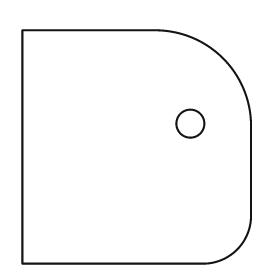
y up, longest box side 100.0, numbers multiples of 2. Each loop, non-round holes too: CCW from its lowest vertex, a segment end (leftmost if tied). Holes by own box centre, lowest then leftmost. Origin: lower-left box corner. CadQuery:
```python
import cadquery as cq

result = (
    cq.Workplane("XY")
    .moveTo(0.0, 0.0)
    .lineTo(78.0, 0.0)
    .threePointArc((92.0, 6.0), (98.0, 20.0))
    .lineTo(98.0, 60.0)
    .threePointArc((86.0, 88.0), (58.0, 100.0))
    .lineTo(0.0, 100.0)
    .close()
    .moveTo(72.0, 60.0)
    .circle(6.0)
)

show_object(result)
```